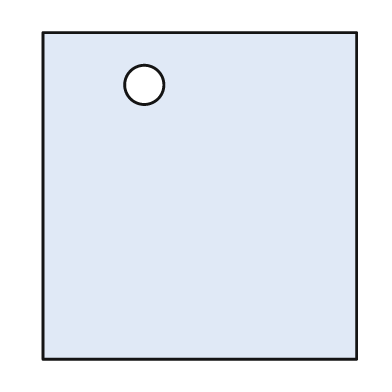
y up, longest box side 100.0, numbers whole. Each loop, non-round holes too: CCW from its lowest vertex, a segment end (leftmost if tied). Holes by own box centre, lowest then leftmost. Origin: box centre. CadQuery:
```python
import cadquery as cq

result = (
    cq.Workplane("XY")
    .moveTo(-48.0, -50.0)
    .lineTo(48.0, -50.0)
    .lineTo(48.0, 50.0)
    .lineTo(-48.0, 50.0)
    .close()
    .moveTo(-17.0, 34.0)
    .circle(6.0)
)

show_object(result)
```